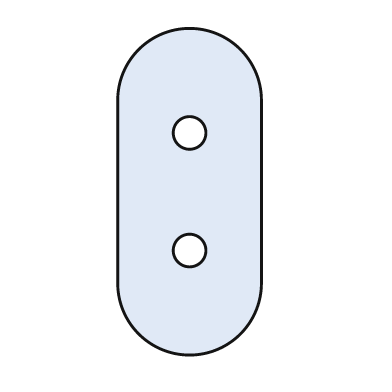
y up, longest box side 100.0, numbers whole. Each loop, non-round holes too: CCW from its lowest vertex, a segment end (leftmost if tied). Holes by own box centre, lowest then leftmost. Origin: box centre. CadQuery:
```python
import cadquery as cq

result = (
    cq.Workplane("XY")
    .moveTo(-22.0, -28.0)
    .threePointArc((0.0, -50.0), (22.0, -28.0))
    .lineTo(22.0, 28.0)
    .threePointArc((0.0, 50.0), (-22.0, 28.0))
    .close()
    .moveTo(0.0, -18.0)
    .circle(5.0)
    .moveTo(0.0, 18.0)
    .circle(5.0)
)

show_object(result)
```